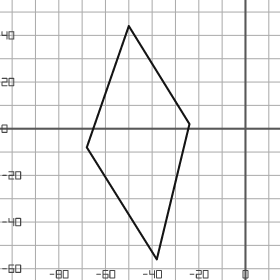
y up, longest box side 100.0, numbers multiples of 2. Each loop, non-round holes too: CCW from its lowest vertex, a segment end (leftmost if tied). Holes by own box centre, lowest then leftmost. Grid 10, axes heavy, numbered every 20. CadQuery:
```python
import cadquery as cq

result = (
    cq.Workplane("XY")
    .moveTo(-38.0, -56.0)
    .lineTo(-24.0, 2.0)
    .lineTo(-50.0, 44.0)
    .lineTo(-68.0, -8.0)
    .close()
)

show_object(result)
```